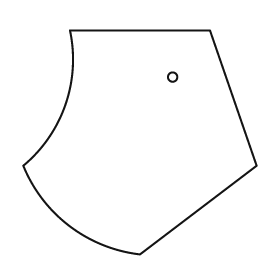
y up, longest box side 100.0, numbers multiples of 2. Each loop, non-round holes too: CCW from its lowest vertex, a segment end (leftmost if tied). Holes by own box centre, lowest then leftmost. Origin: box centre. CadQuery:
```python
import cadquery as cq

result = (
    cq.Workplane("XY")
    .moveTo(0.0, -48.0)
    .lineTo(50.0, -10.0)
    .lineTo(30.0, 48.0)
    .lineTo(-30.0, 48.0)
    .threePointArc((-32.0, 16.0), (-50.0, -10.0))
    .threePointArc((-30.0, -36.0), (0.0, -48.0))
    .close()
    .moveTo(14.0, 28.0)
    .circle(2.0)
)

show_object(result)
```